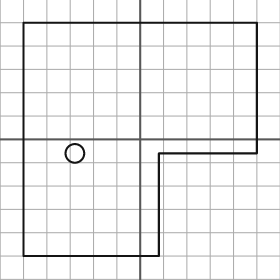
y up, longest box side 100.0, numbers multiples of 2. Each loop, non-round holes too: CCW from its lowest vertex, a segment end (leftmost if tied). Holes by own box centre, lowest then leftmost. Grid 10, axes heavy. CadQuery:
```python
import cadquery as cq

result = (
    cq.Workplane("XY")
    .moveTo(-50.0, -50.0)
    .lineTo(8.0, -50.0)
    .lineTo(8.0, -6.0)
    .lineTo(50.0, -6.0)
    .lineTo(50.0, 50.0)
    .lineTo(-50.0, 50.0)
    .close()
    .moveTo(-28.0, -6.0)
    .circle(4.0)
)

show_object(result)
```